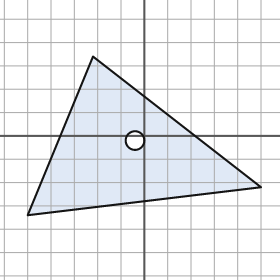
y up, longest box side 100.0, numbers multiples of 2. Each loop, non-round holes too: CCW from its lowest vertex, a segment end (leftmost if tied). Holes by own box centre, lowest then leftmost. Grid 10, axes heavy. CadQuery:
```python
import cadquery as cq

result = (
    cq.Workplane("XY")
    .moveTo(-50.0, -34.0)
    .lineTo(50.0, -22.0)
    .lineTo(-22.0, 34.0)
    .close()
    .moveTo(-4.0, -2.0)
    .circle(4.0)
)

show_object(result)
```